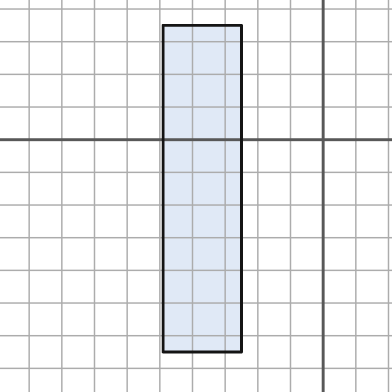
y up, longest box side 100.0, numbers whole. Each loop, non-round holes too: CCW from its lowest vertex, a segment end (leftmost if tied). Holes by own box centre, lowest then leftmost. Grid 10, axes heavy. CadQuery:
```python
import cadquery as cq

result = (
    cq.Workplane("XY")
    .moveTo(-49.0, -65.0)
    .lineTo(-25.0, -65.0)
    .lineTo(-25.0, 35.0)
    .lineTo(-49.0, 35.0)
    .close()
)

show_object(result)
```